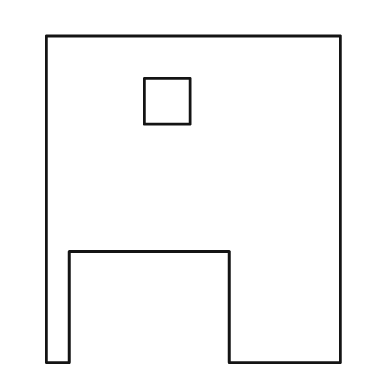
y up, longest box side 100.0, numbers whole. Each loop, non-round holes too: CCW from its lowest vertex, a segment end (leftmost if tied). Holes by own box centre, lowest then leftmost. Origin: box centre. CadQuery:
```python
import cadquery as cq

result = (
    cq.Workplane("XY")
    .moveTo(-45.0, -50.0)
    .lineTo(-38.0, -50.0)
    .lineTo(-38.0, -16.0)
    .lineTo(11.0, -16.0)
    .lineTo(11.0, -50.0)
    .lineTo(45.0, -50.0)
    .lineTo(45.0, 50.0)
    .lineTo(-45.0, 50.0)
    .close()
    .moveTo(-15.0, 23.0)
    .lineTo(-1.0, 23.0)
    .lineTo(-1.0, 37.0)
    .lineTo(-15.0, 37.0)
    .close()
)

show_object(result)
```